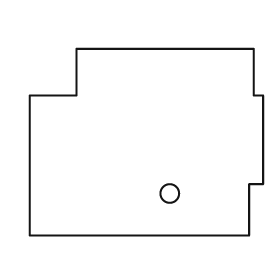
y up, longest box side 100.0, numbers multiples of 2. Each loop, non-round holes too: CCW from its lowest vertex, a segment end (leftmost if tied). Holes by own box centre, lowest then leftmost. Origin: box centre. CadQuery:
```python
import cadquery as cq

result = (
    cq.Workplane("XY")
    .moveTo(-50.0, -40.0)
    .lineTo(44.0, -40.0)
    .lineTo(44.0, -18.0)
    .lineTo(50.0, -18.0)
    .lineTo(50.0, 20.0)
    .lineTo(46.0, 20.0)
    .lineTo(46.0, 40.0)
    .lineTo(-30.0, 40.0)
    .lineTo(-30.0, 20.0)
    .lineTo(-50.0, 20.0)
    .close()
    .moveTo(10.0, -22.0)
    .circle(4.0)
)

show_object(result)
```